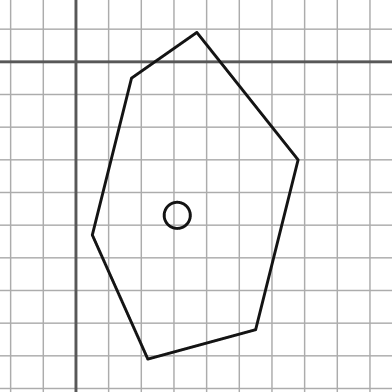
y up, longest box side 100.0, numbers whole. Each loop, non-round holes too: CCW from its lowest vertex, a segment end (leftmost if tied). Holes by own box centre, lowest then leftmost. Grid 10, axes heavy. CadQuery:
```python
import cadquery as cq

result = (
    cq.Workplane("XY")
    .moveTo(22.0, -91.0)
    .lineTo(55.0, -82.0)
    .lineTo(68.0, -30.0)
    .lineTo(37.0, 9.0)
    .lineTo(17.0, -5.0)
    .lineTo(5.0, -53.0)
    .close()
    .moveTo(31.0, -47.0)
    .circle(4.0)
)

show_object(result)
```